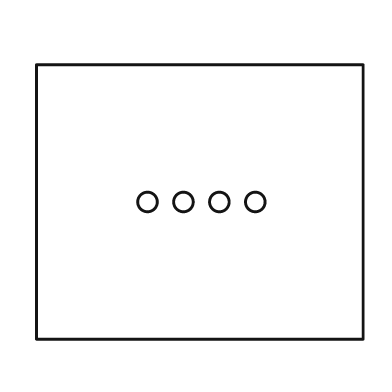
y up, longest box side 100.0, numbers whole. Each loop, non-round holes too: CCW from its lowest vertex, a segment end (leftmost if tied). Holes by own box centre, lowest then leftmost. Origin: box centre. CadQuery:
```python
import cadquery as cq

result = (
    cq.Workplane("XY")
    .moveTo(-50.0, -42.0)
    .lineTo(50.0, -42.0)
    .lineTo(50.0, 42.0)
    .lineTo(-50.0, 42.0)
    .close()
    .moveTo(-16.0, 0.0)
    .circle(3.0)
    .moveTo(-5.0, 0.0)
    .circle(3.0)
    .moveTo(6.0, 0.0)
    .circle(3.0)
    .moveTo(17.0, 0.0)
    .circle(3.0)
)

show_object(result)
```